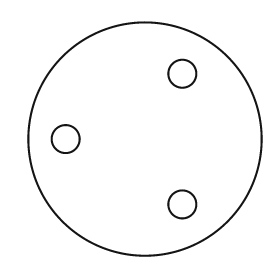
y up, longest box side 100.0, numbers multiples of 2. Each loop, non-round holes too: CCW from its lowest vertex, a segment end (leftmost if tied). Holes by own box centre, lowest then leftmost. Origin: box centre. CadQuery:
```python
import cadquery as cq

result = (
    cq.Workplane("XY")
    .moveTo(0.0, 0.0)
    .circle(50.0)
    .moveTo(16.0, -28.0)
    .circle(6.0)
    .moveTo(-34.0, 0.0)
    .circle(6.0)
    .moveTo(16.0, 28.0)
    .circle(6.0)
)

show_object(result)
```